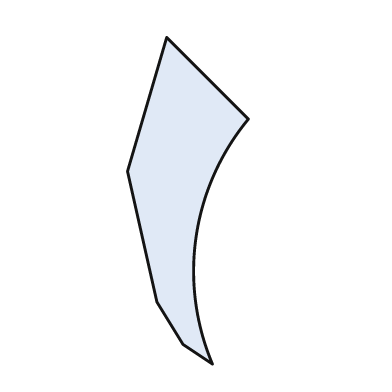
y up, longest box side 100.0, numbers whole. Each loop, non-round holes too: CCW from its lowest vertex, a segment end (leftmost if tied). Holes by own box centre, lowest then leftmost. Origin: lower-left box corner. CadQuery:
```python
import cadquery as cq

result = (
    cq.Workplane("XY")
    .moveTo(26.0, 0.0)
    .threePointArc((21.0, 39.0), (37.0, 75.0))
    .lineTo(12.0, 100.0)
    .lineTo(0.0, 59.0)
    .lineTo(9.0, 19.0)
    .lineTo(17.0, 6.0)
    .close()
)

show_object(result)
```